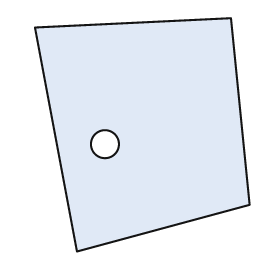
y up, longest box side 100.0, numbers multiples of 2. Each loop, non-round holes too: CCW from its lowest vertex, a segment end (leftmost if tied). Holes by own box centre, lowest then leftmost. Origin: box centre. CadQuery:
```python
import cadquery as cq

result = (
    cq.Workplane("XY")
    .moveTo(-28.0, -50.0)
    .lineTo(46.0, -30.0)
    .lineTo(38.0, 50.0)
    .lineTo(-46.0, 46.0)
    .close()
    .moveTo(-16.0, -4.0)
    .circle(6.0)
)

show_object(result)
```